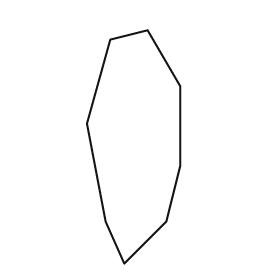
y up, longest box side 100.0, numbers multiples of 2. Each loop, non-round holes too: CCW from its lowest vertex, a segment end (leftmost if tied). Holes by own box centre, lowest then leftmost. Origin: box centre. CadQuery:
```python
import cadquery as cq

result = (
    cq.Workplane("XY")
    .moveTo(-4.0, -50.0)
    .lineTo(14.0, -32.0)
    .lineTo(20.0, -8.0)
    .lineTo(20.0, 26.0)
    .lineTo(6.0, 50.0)
    .lineTo(-10.0, 46.0)
    .lineTo(-20.0, 10.0)
    .lineTo(-12.0, -32.0)
    .close()
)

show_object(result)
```